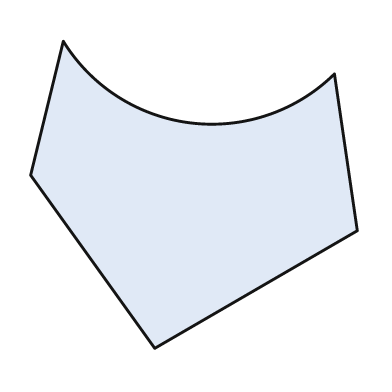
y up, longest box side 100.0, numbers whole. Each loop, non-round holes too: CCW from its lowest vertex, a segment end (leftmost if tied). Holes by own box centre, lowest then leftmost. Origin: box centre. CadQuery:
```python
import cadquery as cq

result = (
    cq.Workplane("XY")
    .moveTo(-12.0, -47.0)
    .lineTo(50.0, -11.0)
    .lineTo(43.0, 37.0)
    .threePointArc((-1.0, 22.0), (-40.0, 47.0))
    .lineTo(-50.0, 6.0)
    .close()
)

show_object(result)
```